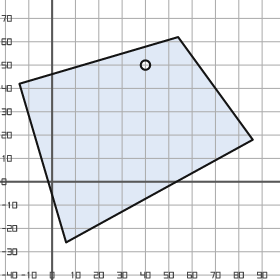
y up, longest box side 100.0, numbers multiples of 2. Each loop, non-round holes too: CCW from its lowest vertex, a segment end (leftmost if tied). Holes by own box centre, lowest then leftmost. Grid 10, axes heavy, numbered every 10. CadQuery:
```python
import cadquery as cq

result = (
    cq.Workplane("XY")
    .moveTo(6.0, -26.0)
    .lineTo(86.0, 18.0)
    .lineTo(54.0, 62.0)
    .lineTo(-14.0, 42.0)
    .close()
    .moveTo(40.0, 50.0)
    .circle(2.0)
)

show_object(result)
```